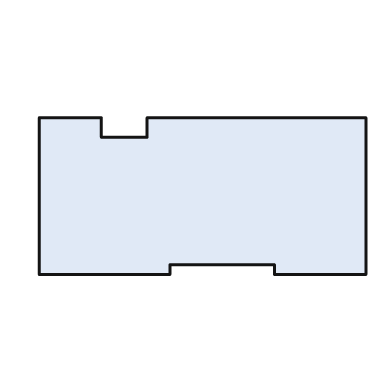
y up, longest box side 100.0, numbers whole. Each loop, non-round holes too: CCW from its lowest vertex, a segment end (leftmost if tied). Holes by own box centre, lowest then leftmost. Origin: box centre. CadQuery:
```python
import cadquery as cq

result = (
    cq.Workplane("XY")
    .moveTo(-50.0, -24.0)
    .lineTo(-10.0, -24.0)
    .lineTo(-10.0, -21.0)
    .lineTo(22.0, -21.0)
    .lineTo(22.0, -24.0)
    .lineTo(50.0, -24.0)
    .lineTo(50.0, 24.0)
    .lineTo(-17.0, 24.0)
    .lineTo(-17.0, 18.0)
    .lineTo(-31.0, 18.0)
    .lineTo(-31.0, 24.0)
    .lineTo(-50.0, 24.0)
    .close()
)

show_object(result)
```